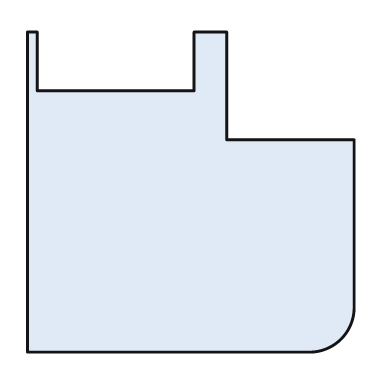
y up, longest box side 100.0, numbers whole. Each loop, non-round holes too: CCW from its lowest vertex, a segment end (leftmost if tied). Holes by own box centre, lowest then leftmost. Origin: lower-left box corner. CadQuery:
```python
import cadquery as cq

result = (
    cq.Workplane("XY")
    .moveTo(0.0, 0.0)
    .lineTo(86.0, 0.0)
    .threePointArc((96.0, 4.0), (100.0, 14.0))
    .lineTo(100.0, 65.0)
    .lineTo(61.0, 65.0)
    .lineTo(61.0, 98.0)
    .lineTo(51.0, 98.0)
    .lineTo(51.0, 80.0)
    .lineTo(3.0, 80.0)
    .lineTo(3.0, 98.0)
    .lineTo(0.0, 98.0)
    .close()
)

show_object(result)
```